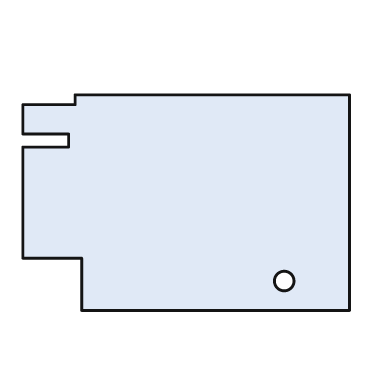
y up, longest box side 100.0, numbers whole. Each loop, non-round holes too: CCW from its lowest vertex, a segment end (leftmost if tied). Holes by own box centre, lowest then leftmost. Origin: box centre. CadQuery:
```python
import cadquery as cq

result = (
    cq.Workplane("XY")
    .moveTo(-32.0, -33.0)
    .lineTo(50.0, -33.0)
    .lineTo(50.0, 33.0)
    .lineTo(-34.0, 33.0)
    .lineTo(-34.0, 30.0)
    .lineTo(-50.0, 30.0)
    .lineTo(-50.0, 21.0)
    .lineTo(-36.0, 21.0)
    .lineTo(-36.0, 17.0)
    .lineTo(-50.0, 17.0)
    .lineTo(-50.0, -17.0)
    .lineTo(-32.0, -17.0)
    .close()
    .moveTo(30.0, -24.0)
    .circle(3.0)
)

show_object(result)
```